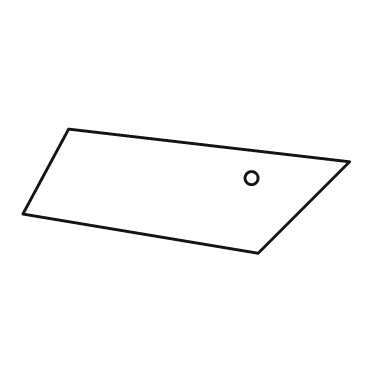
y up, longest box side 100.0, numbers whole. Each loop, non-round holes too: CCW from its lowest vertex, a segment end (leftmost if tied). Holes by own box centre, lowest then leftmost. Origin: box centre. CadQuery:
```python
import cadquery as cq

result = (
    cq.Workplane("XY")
    .moveTo(22.0, -19.0)
    .lineTo(50.0, 9.0)
    .lineTo(-36.0, 19.0)
    .lineTo(-50.0, -7.0)
    .close()
    .moveTo(20.0, 4.0)
    .circle(2.0)
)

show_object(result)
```